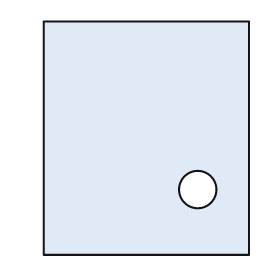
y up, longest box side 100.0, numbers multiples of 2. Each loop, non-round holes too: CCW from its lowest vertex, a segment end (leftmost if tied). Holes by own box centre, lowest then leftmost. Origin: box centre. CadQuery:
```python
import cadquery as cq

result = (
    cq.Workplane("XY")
    .moveTo(-44.0, -50.0)
    .lineTo(44.0, -50.0)
    .lineTo(44.0, 50.0)
    .lineTo(-44.0, 50.0)
    .close()
    .moveTo(22.0, -22.0)
    .circle(8.0)
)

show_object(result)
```